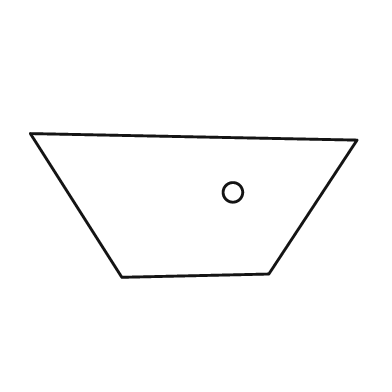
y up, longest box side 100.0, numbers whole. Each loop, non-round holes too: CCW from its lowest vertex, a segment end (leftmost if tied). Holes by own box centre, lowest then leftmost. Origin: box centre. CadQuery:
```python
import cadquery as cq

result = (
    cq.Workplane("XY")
    .moveTo(-22.0, -22.0)
    .lineTo(23.0, -21.0)
    .lineTo(50.0, 20.0)
    .lineTo(-50.0, 22.0)
    .close()
    .moveTo(12.0, 4.0)
    .circle(3.0)
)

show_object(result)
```